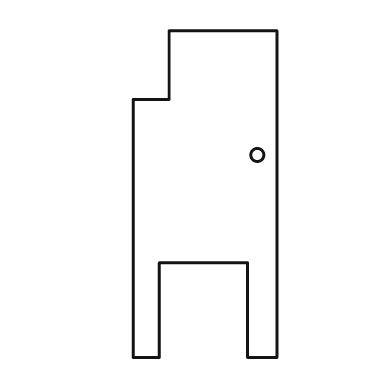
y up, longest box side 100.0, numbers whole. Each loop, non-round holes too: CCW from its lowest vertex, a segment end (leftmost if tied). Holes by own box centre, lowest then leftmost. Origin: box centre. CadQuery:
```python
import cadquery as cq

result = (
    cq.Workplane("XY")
    .moveTo(-22.0, -50.0)
    .lineTo(-14.0, -50.0)
    .lineTo(-14.0, -21.0)
    .lineTo(13.0, -21.0)
    .lineTo(13.0, -50.0)
    .lineTo(22.0, -50.0)
    .lineTo(22.0, 50.0)
    .lineTo(-11.0, 50.0)
    .lineTo(-11.0, 29.0)
    .lineTo(-22.0, 29.0)
    .close()
    .moveTo(16.0, 12.0)
    .circle(2.0)
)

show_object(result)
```